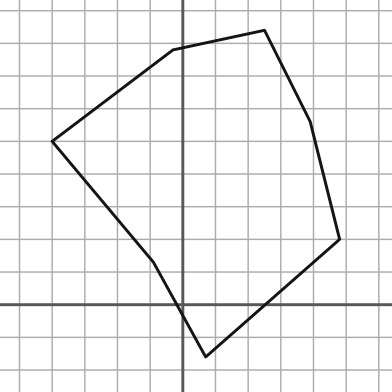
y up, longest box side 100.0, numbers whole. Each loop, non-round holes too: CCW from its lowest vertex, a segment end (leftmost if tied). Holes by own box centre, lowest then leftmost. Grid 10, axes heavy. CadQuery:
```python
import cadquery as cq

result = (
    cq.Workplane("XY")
    .moveTo(7.0, -16.0)
    .lineTo(48.0, 20.0)
    .lineTo(39.0, 56.0)
    .lineTo(25.0, 84.0)
    .lineTo(-3.0, 78.0)
    .lineTo(-40.0, 50.0)
    .lineTo(-9.0, 13.0)
    .close()
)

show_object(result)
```